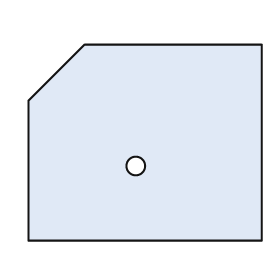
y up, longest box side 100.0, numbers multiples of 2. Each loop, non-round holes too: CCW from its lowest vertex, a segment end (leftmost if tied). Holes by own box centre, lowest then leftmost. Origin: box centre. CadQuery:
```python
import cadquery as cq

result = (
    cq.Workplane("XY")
    .moveTo(-50.0, -42.0)
    .lineTo(50.0, -42.0)
    .lineTo(50.0, 42.0)
    .lineTo(-26.0, 42.0)
    .lineTo(-50.0, 18.0)
    .close()
    .moveTo(-4.0, -10.0)
    .circle(4.0)
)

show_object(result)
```